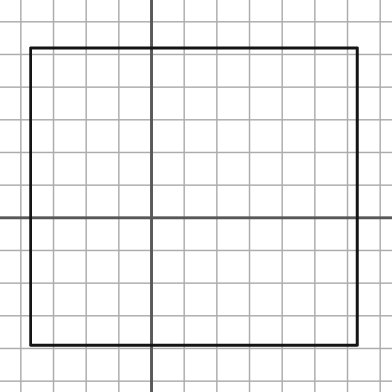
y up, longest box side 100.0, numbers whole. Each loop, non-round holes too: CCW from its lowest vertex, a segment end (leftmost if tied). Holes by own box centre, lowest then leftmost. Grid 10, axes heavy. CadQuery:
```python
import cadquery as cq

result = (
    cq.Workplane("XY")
    .moveTo(-37.0, -39.0)
    .lineTo(63.0, -39.0)
    .lineTo(63.0, 52.0)
    .lineTo(-37.0, 52.0)
    .close()
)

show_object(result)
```